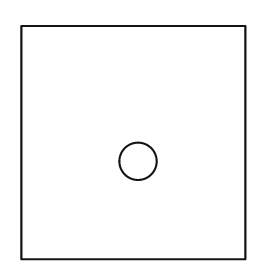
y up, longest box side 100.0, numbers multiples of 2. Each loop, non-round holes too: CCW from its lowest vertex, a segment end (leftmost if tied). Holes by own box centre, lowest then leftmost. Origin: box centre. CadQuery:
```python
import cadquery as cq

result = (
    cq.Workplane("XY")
    .moveTo(-48.0, -50.0)
    .lineTo(48.0, -50.0)
    .lineTo(48.0, 50.0)
    .lineTo(-48.0, 50.0)
    .close()
    .moveTo(2.0, -8.0)
    .circle(8.0)
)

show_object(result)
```